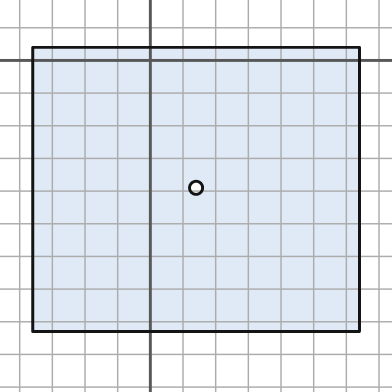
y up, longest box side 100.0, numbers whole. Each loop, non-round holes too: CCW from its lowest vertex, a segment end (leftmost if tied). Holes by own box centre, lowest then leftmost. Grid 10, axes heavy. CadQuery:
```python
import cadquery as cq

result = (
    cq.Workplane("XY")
    .moveTo(-36.0, -83.0)
    .lineTo(64.0, -83.0)
    .lineTo(64.0, 4.0)
    .lineTo(-36.0, 4.0)
    .close()
    .moveTo(14.0, -39.0)
    .circle(2.0)
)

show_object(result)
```